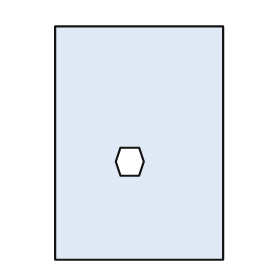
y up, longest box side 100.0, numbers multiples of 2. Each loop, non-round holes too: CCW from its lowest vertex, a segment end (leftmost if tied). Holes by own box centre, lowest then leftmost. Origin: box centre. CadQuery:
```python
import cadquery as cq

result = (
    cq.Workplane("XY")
    .moveTo(-36.0, -50.0)
    .lineTo(36.0, -50.0)
    .lineTo(36.0, 50.0)
    .lineTo(-36.0, 50.0)
    .close()
    .moveTo(-8.0, -14.0)
    .lineTo(0.0, -14.0)
    .lineTo(2.0, -8.0)
    .lineTo(0.0, -2.0)
    .lineTo(-8.0, -2.0)
    .lineTo(-10.0, -8.0)
    .close()
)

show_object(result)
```